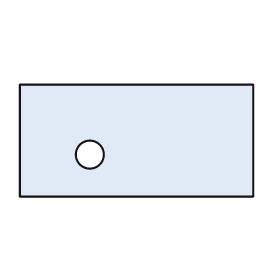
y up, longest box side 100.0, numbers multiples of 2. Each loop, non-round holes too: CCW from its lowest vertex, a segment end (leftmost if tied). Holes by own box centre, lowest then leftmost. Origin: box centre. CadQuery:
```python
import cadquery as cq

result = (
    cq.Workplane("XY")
    .moveTo(-50.0, -24.0)
    .lineTo(50.0, -24.0)
    .lineTo(50.0, 24.0)
    .lineTo(-50.0, 24.0)
    .close()
    .moveTo(-20.0, -6.0)
    .circle(6.0)
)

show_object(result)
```